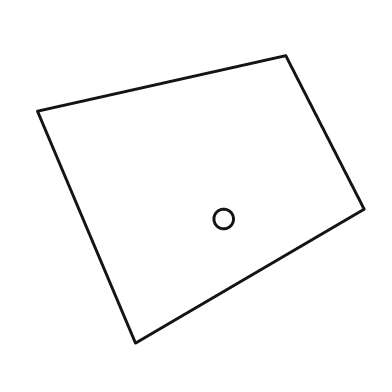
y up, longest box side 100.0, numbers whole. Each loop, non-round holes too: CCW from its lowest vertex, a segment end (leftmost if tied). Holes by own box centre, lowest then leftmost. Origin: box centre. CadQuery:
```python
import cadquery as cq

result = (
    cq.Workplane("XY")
    .moveTo(-20.0, -44.0)
    .lineTo(50.0, -3.0)
    .lineTo(26.0, 44.0)
    .lineTo(-50.0, 27.0)
    .close()
    .moveTo(7.0, -6.0)
    .circle(3.0)
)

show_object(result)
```